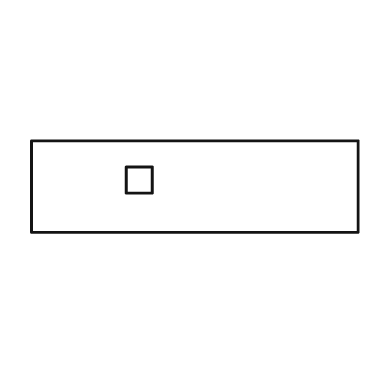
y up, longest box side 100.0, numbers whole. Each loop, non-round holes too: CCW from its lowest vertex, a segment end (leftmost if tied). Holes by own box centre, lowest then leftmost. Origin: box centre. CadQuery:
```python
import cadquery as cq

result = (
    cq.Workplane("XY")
    .moveTo(-50.0, -14.0)
    .lineTo(50.0, -14.0)
    .lineTo(50.0, 14.0)
    .lineTo(-50.0, 14.0)
    .close()
    .moveTo(-21.0, -2.0)
    .lineTo(-13.0, -2.0)
    .lineTo(-13.0, 6.0)
    .lineTo(-21.0, 6.0)
    .close()
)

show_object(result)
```